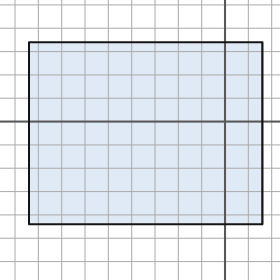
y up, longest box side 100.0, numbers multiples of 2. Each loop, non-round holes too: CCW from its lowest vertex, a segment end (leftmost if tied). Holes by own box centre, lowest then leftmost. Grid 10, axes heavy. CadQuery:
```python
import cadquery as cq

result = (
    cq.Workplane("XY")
    .moveTo(-84.0, -44.0)
    .lineTo(16.0, -44.0)
    .lineTo(16.0, 34.0)
    .lineTo(-84.0, 34.0)
    .close()
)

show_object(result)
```